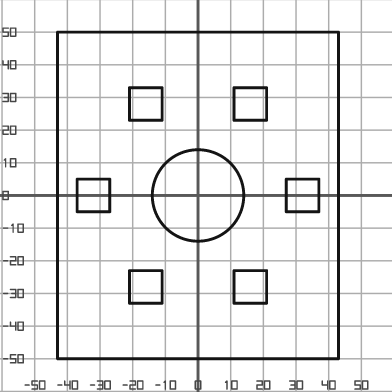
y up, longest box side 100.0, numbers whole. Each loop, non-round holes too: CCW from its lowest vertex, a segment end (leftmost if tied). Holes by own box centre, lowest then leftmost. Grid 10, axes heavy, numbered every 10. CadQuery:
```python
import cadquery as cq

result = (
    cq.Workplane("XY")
    .moveTo(-43.0, -50.0)
    .lineTo(43.0, -50.0)
    .lineTo(43.0, 50.0)
    .lineTo(-43.0, 50.0)
    .close()
    .moveTo(-21.0, -33.0)
    .lineTo(-11.0, -33.0)
    .lineTo(-11.0, -23.0)
    .lineTo(-21.0, -23.0)
    .close()
    .moveTo(11.0, -33.0)
    .lineTo(21.0, -33.0)
    .lineTo(21.0, -23.0)
    .lineTo(11.0, -23.0)
    .close()
    .moveTo(-37.0, -5.0)
    .lineTo(-27.0, -5.0)
    .lineTo(-27.0, 5.0)
    .lineTo(-37.0, 5.0)
    .close()
    .moveTo(0.0, 0.0)
    .circle(14.0)
    .moveTo(27.0, -5.0)
    .lineTo(37.0, -5.0)
    .lineTo(37.0, 5.0)
    .lineTo(27.0, 5.0)
    .close()
    .moveTo(-21.0, 23.0)
    .lineTo(-11.0, 23.0)
    .lineTo(-11.0, 33.0)
    .lineTo(-21.0, 33.0)
    .close()
    .moveTo(11.0, 23.0)
    .lineTo(21.0, 23.0)
    .lineTo(21.0, 33.0)
    .lineTo(11.0, 33.0)
    .close()
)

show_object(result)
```